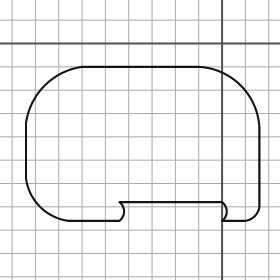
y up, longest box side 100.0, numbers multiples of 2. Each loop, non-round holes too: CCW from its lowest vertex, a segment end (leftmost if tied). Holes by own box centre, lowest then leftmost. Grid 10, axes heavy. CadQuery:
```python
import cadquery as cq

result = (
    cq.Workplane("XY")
    .moveTo(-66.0, -76.0)
    .lineTo(-44.0, -76.0)
    .threePointArc((-42.0, -72.0), (-44.0, -68.0))
    .lineTo(0.0, -68.0)
    .threePointArc((2.0, -72.0), (0.0, -76.0))
    .lineTo(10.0, -76.0)
    .threePointArc((14.0, -74.0), (16.0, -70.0))
    .lineTo(16.0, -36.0)
    .threePointArc((8.0, -18.0), (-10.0, -10.0))
    .lineTo(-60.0, -10.0)
    .threePointArc((-76.0, -18.0), (-84.0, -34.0))
    .lineTo(-84.0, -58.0)
    .threePointArc((-78.0, -70.0), (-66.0, -76.0))
    .close()
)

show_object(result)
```